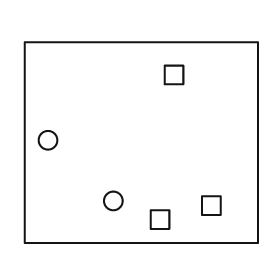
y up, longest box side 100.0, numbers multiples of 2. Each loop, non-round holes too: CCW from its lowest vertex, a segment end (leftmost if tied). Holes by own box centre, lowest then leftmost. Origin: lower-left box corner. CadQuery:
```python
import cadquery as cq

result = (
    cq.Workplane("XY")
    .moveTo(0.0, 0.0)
    .lineTo(100.0, 0.0)
    .lineTo(100.0, 86.0)
    .lineTo(0.0, 86.0)
    .close()
    .moveTo(54.0, 6.0)
    .lineTo(62.0, 6.0)
    .lineTo(62.0, 14.0)
    .lineTo(54.0, 14.0)
    .close()
    .moveTo(76.0, 12.0)
    .lineTo(84.0, 12.0)
    .lineTo(84.0, 20.0)
    .lineTo(76.0, 20.0)
    .close()
    .moveTo(38.0, 18.0)
    .circle(4.0)
    .moveTo(10.0, 44.0)
    .circle(4.0)
    .moveTo(60.0, 68.0)
    .lineTo(68.0, 68.0)
    .lineTo(68.0, 76.0)
    .lineTo(60.0, 76.0)
    .close()
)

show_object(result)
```